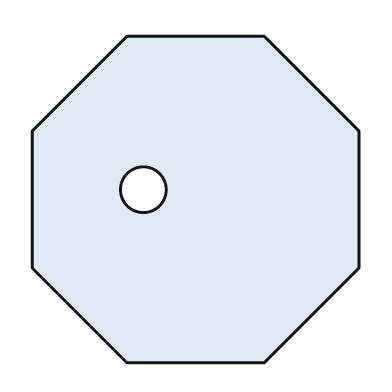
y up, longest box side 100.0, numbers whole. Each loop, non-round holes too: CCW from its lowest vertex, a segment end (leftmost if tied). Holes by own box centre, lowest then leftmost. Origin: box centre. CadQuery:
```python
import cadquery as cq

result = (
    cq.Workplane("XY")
    .moveTo(-21.0, -50.0)
    .lineTo(21.0, -50.0)
    .lineTo(50.0, -21.0)
    .lineTo(50.0, 21.0)
    .lineTo(21.0, 50.0)
    .lineTo(-21.0, 50.0)
    .lineTo(-50.0, 21.0)
    .lineTo(-50.0, -21.0)
    .close()
    .moveTo(-16.0, 3.0)
    .circle(7.0)
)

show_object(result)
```